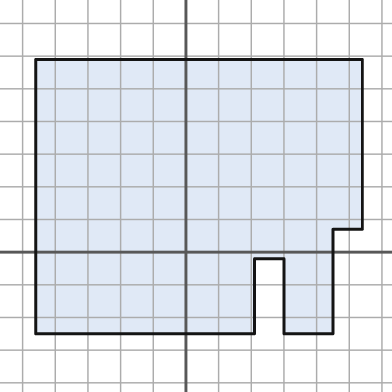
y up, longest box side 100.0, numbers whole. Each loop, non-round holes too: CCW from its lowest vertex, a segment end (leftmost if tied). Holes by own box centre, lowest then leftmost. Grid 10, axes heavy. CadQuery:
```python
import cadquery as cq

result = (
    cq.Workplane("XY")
    .moveTo(-46.0, -25.0)
    .lineTo(21.0, -25.0)
    .lineTo(21.0, -2.0)
    .lineTo(30.0, -2.0)
    .lineTo(30.0, -25.0)
    .lineTo(45.0, -25.0)
    .lineTo(45.0, 7.0)
    .lineTo(54.0, 7.0)
    .lineTo(54.0, 59.0)
    .lineTo(-46.0, 59.0)
    .close()
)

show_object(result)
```